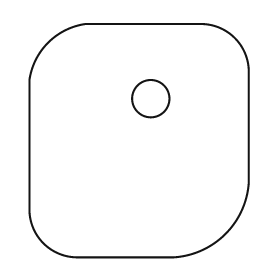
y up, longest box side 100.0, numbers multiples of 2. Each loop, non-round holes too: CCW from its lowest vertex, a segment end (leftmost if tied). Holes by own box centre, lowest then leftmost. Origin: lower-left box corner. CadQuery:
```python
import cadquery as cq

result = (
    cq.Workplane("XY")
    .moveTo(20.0, 0.0)
    .lineTo(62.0, 0.0)
    .threePointArc((84.0, 10.0), (94.0, 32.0))
    .lineTo(94.0, 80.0)
    .threePointArc((88.0, 94.0), (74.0, 100.0))
    .lineTo(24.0, 100.0)
    .threePointArc((8.0, 92.0), (0.0, 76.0))
    .lineTo(0.0, 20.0)
    .threePointArc((6.0, 6.0), (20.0, 0.0))
    .close()
    .moveTo(52.0, 68.0)
    .circle(8.0)
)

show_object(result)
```